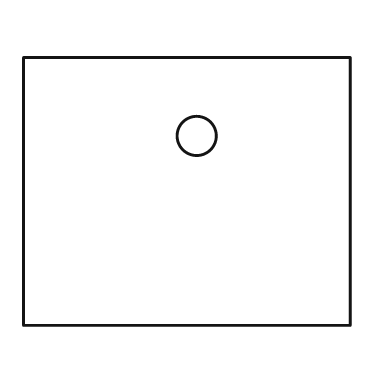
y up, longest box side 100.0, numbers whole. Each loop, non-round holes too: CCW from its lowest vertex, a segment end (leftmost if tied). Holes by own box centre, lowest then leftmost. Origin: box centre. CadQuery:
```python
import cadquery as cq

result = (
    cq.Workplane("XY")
    .moveTo(-50.0, -41.0)
    .lineTo(50.0, -41.0)
    .lineTo(50.0, 41.0)
    .lineTo(-50.0, 41.0)
    .close()
    .moveTo(3.0, 17.0)
    .circle(6.0)
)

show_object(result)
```